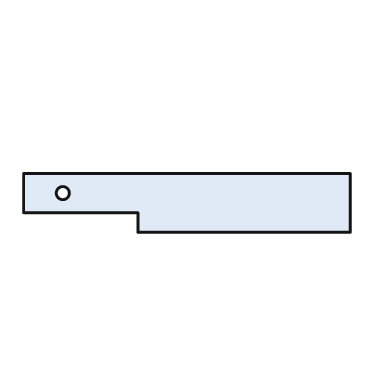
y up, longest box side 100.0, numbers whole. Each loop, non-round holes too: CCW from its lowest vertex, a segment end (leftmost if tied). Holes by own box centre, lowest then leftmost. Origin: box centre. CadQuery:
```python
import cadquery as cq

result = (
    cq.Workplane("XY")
    .moveTo(-15.0, -9.0)
    .lineTo(50.0, -9.0)
    .lineTo(50.0, 9.0)
    .lineTo(-50.0, 9.0)
    .lineTo(-50.0, -3.0)
    .lineTo(-15.0, -3.0)
    .close()
    .moveTo(-38.0, 3.0)
    .circle(2.0)
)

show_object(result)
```